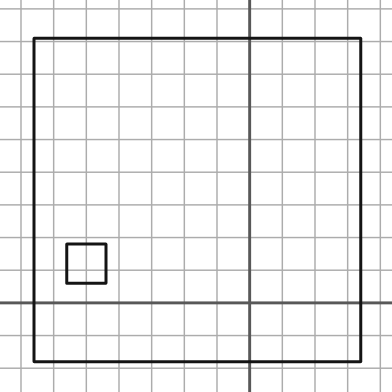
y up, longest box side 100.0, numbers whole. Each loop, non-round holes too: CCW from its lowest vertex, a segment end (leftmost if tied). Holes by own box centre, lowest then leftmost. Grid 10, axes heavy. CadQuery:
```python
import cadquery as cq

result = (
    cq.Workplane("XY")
    .moveTo(-66.0, -18.0)
    .lineTo(34.0, -18.0)
    .lineTo(34.0, 81.0)
    .lineTo(-66.0, 81.0)
    .close()
    .moveTo(-56.0, 6.0)
    .lineTo(-44.0, 6.0)
    .lineTo(-44.0, 18.0)
    .lineTo(-56.0, 18.0)
    .close()
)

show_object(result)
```